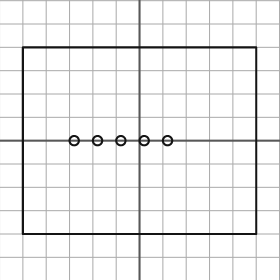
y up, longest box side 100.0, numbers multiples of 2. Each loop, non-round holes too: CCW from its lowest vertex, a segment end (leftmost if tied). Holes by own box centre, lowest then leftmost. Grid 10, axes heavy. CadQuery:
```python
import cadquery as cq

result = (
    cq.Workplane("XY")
    .moveTo(-50.0, -40.0)
    .lineTo(50.0, -40.0)
    .lineTo(50.0, 40.0)
    .lineTo(-50.0, 40.0)
    .close()
    .moveTo(-28.0, 0.0)
    .circle(2.0)
    .moveTo(-18.0, 0.0)
    .circle(2.0)
    .moveTo(-8.0, 0.0)
    .circle(2.0)
    .moveTo(2.0, 0.0)
    .circle(2.0)
    .moveTo(12.0, 0.0)
    .circle(2.0)
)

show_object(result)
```